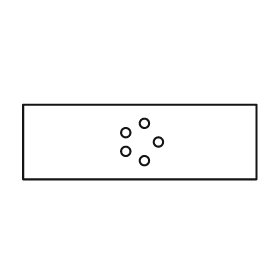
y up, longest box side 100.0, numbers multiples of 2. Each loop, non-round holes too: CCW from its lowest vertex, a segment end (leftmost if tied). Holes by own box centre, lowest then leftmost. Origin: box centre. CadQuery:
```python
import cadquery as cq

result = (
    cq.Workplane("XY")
    .moveTo(-50.0, -16.0)
    .lineTo(50.0, -16.0)
    .lineTo(50.0, 16.0)
    .lineTo(-50.0, 16.0)
    .close()
    .moveTo(2.0, -8.0)
    .circle(2.0)
    .moveTo(-6.0, -4.0)
    .circle(2.0)
    .moveTo(8.0, 0.0)
    .circle(2.0)
    .moveTo(-6.0, 4.0)
    .circle(2.0)
    .moveTo(2.0, 8.0)
    .circle(2.0)
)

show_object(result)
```